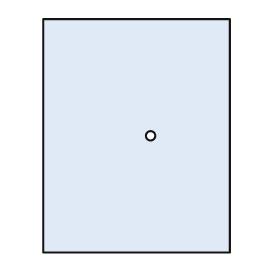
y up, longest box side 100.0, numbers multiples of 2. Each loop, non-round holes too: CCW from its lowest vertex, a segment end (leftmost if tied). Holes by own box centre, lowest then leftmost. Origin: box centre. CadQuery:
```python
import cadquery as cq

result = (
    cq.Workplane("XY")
    .moveTo(-40.0, -50.0)
    .lineTo(40.0, -50.0)
    .lineTo(40.0, 50.0)
    .lineTo(-40.0, 50.0)
    .close()
    .moveTo(6.0, 0.0)
    .circle(2.0)
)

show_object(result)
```